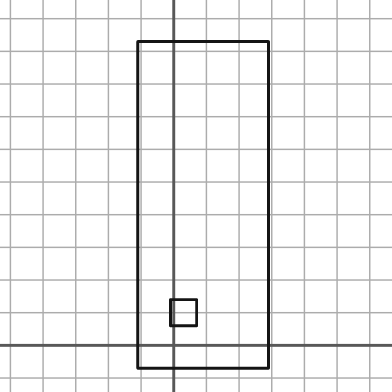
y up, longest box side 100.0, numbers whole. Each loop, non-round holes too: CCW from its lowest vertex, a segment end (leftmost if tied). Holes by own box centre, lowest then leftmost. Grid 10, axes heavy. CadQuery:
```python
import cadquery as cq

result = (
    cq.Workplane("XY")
    .moveTo(-11.0, -7.0)
    .lineTo(29.0, -7.0)
    .lineTo(29.0, 93.0)
    .lineTo(-11.0, 93.0)
    .close()
    .moveTo(-1.0, 6.0)
    .lineTo(7.0, 6.0)
    .lineTo(7.0, 14.0)
    .lineTo(-1.0, 14.0)
    .close()
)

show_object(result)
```